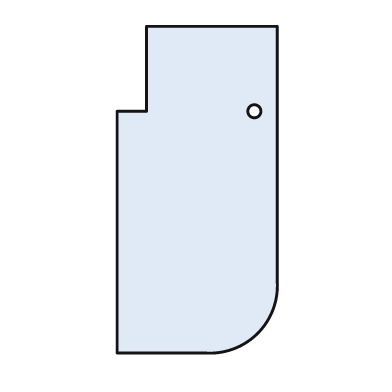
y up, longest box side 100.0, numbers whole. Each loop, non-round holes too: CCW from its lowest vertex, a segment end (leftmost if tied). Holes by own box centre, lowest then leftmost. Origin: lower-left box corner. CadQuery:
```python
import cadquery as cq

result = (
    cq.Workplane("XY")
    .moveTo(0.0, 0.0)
    .lineTo(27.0, 0.0)
    .threePointArc((43.0, 6.0), (49.0, 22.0))
    .lineTo(49.0, 100.0)
    .lineTo(9.0, 100.0)
    .lineTo(9.0, 74.0)
    .lineTo(0.0, 74.0)
    .close()
    .moveTo(42.0, 74.0)
    .circle(2.0)
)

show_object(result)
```